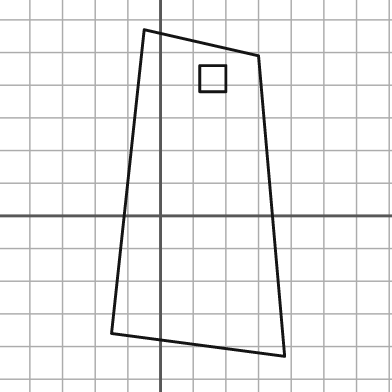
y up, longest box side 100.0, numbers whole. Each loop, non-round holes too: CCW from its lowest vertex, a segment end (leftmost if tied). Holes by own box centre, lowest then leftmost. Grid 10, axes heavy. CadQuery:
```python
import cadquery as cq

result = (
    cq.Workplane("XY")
    .moveTo(38.0, -43.0)
    .lineTo(30.0, 49.0)
    .lineTo(-5.0, 57.0)
    .lineTo(-15.0, -36.0)
    .close()
    .moveTo(12.0, 38.0)
    .lineTo(20.0, 38.0)
    .lineTo(20.0, 46.0)
    .lineTo(12.0, 46.0)
    .close()
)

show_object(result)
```